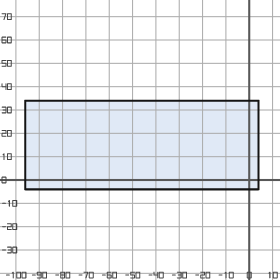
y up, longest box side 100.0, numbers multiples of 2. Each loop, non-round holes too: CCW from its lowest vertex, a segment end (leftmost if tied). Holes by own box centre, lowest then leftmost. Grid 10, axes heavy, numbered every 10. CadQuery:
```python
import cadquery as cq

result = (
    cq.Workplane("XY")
    .moveTo(-96.0, -4.0)
    .lineTo(4.0, -4.0)
    .lineTo(4.0, 34.0)
    .lineTo(-96.0, 34.0)
    .close()
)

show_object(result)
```